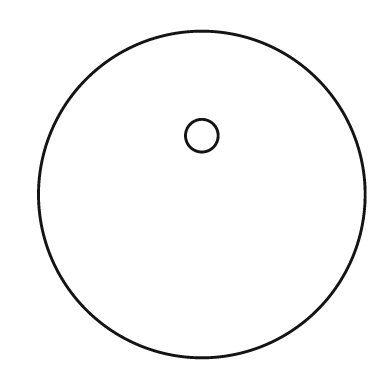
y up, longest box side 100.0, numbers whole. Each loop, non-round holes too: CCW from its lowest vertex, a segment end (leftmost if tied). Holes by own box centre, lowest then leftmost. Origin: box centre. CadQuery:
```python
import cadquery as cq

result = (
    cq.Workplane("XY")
    .moveTo(0.0, 0.0)
    .circle(50.0)
    .moveTo(0.0, 18.0)
    .circle(5.0)
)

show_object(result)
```